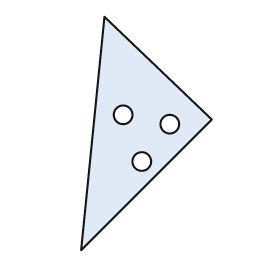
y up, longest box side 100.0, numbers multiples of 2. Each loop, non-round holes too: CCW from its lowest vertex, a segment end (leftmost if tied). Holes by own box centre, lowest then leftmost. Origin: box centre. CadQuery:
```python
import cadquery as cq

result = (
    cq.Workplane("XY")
    .moveTo(-28.0, -50.0)
    .lineTo(28.0, 6.0)
    .lineTo(-18.0, 50.0)
    .close()
    .moveTo(-2.0, -12.0)
    .circle(4.0)
    .moveTo(10.0, 4.0)
    .circle(4.0)
    .moveTo(-10.0, 8.0)
    .circle(4.0)
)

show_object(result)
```